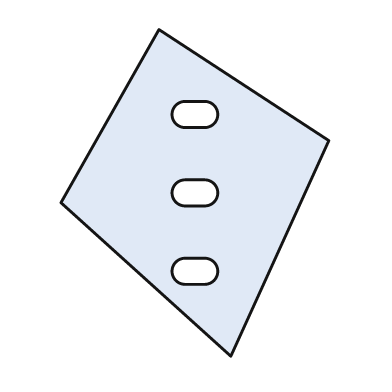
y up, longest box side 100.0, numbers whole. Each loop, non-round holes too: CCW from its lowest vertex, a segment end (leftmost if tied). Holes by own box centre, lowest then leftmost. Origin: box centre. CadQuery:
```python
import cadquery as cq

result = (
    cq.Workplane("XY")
    .moveTo(11.0, -50.0)
    .lineTo(41.0, 16.0)
    .lineTo(-11.0, 50.0)
    .lineTo(-41.0, -3.0)
    .close()
    .moveTo(-3.0, -28.0)
    .lineTo(3.0, -28.0)
    .threePointArc((7.0, -24.0), (3.0, -20.0))
    .lineTo(-3.0, -20.0)
    .threePointArc((-7.0, -24.0), (-3.0, -28.0))
    .close()
    .moveTo(-3.0, -4.0)
    .lineTo(3.0, -4.0)
    .threePointArc((7.0, 0.0), (3.0, 4.0))
    .lineTo(-3.0, 4.0)
    .threePointArc((-7.0, 0.0), (-3.0, -4.0))
    .close()
    .moveTo(-3.0, 20.0)
    .lineTo(3.0, 20.0)
    .threePointArc((7.0, 24.0), (3.0, 28.0))
    .lineTo(-3.0, 28.0)
    .threePointArc((-7.0, 24.0), (-3.0, 20.0))
    .close()
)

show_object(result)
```